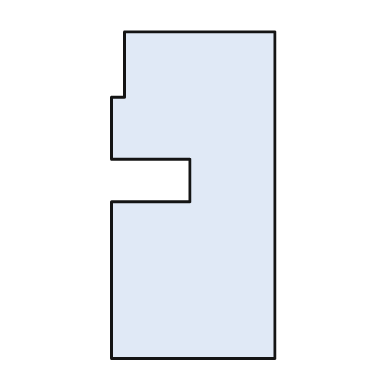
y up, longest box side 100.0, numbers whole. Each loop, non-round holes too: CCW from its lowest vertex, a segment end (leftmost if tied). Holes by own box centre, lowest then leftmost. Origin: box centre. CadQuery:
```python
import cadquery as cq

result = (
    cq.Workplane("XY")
    .moveTo(-25.0, -50.0)
    .lineTo(25.0, -50.0)
    .lineTo(25.0, 50.0)
    .lineTo(-21.0, 50.0)
    .lineTo(-21.0, 30.0)
    .lineTo(-25.0, 30.0)
    .lineTo(-25.0, 11.0)
    .lineTo(-1.0, 11.0)
    .lineTo(-1.0, -2.0)
    .lineTo(-25.0, -2.0)
    .close()
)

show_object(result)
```